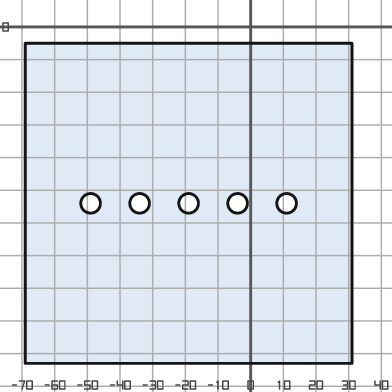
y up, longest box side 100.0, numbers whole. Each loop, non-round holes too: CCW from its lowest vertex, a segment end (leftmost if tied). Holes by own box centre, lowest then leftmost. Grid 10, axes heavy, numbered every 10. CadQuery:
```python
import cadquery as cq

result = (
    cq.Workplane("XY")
    .moveTo(-69.0, -103.0)
    .lineTo(31.0, -103.0)
    .lineTo(31.0, -5.0)
    .lineTo(-69.0, -5.0)
    .close()
    .moveTo(-49.0, -54.0)
    .circle(3.0)
    .moveTo(-34.0, -54.0)
    .circle(3.0)
    .moveTo(-19.0, -54.0)
    .circle(3.0)
    .moveTo(-4.0, -54.0)
    .circle(3.0)
    .moveTo(11.0, -54.0)
    .circle(3.0)
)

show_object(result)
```